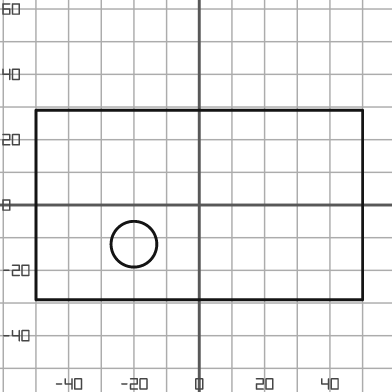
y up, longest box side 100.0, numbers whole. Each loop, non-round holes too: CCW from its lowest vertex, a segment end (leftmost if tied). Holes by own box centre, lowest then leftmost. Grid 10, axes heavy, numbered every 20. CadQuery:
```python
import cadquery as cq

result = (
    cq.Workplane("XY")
    .moveTo(-50.0, -29.0)
    .lineTo(50.0, -29.0)
    .lineTo(50.0, 29.0)
    .lineTo(-50.0, 29.0)
    .close()
    .moveTo(-20.0, -12.0)
    .circle(7.0)
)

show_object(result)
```